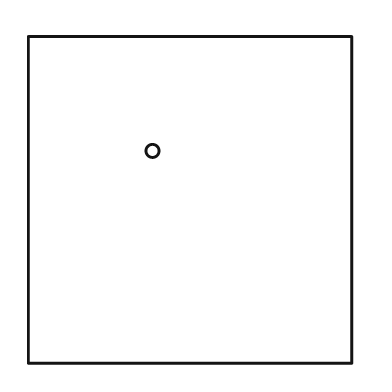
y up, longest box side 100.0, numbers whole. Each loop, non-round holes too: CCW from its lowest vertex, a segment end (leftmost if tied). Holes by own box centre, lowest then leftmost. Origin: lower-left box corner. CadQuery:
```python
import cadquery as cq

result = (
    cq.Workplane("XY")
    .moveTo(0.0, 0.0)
    .lineTo(99.0, 0.0)
    .lineTo(99.0, 100.0)
    .lineTo(0.0, 100.0)
    .close()
    .moveTo(38.0, 65.0)
    .circle(2.0)
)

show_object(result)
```